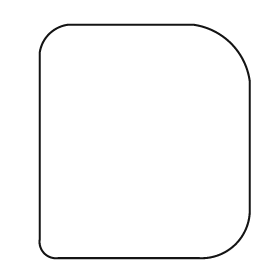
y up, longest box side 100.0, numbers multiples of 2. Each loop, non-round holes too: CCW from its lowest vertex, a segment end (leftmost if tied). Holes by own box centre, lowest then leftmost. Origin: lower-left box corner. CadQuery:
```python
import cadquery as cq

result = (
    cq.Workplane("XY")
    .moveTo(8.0, 0.0)
    .lineTo(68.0, 0.0)
    .threePointArc((84.0, 6.0), (90.0, 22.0))
    .lineTo(90.0, 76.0)
    .threePointArc((82.0, 92.0), (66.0, 100.0))
    .lineTo(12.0, 100.0)
    .threePointArc((4.0, 96.0), (0.0, 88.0))
    .lineTo(0.0, 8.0)
    .threePointArc((2.0, 2.0), (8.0, 0.0))
    .close()
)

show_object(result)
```